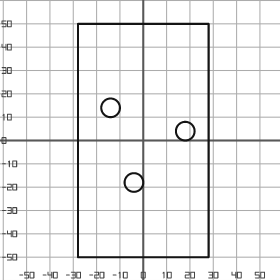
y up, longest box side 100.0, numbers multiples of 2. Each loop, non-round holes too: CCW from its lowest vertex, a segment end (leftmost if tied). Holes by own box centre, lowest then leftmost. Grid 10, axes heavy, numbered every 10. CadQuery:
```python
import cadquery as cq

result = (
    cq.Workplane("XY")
    .moveTo(-28.0, -50.0)
    .lineTo(28.0, -50.0)
    .lineTo(28.0, 50.0)
    .lineTo(-28.0, 50.0)
    .close()
    .moveTo(-4.0, -18.0)
    .circle(4.0)
    .moveTo(18.0, 4.0)
    .circle(4.0)
    .moveTo(-14.0, 14.0)
    .circle(4.0)
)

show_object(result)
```